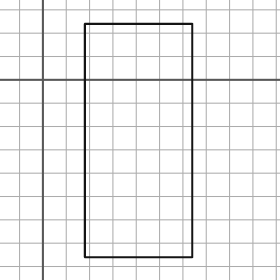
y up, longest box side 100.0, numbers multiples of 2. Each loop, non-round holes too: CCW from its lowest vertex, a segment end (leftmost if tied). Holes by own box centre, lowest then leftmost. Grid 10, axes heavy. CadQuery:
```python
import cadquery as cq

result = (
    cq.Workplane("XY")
    .moveTo(18.0, -76.0)
    .lineTo(64.0, -76.0)
    .lineTo(64.0, 24.0)
    .lineTo(18.0, 24.0)
    .close()
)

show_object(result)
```